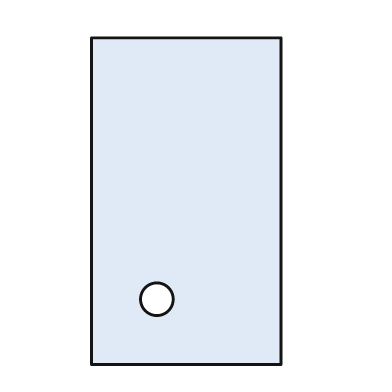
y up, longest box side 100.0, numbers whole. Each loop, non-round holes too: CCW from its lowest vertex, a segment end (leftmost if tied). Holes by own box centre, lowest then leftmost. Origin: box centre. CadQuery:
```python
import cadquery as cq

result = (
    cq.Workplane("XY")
    .moveTo(-29.0, -50.0)
    .lineTo(29.0, -50.0)
    .lineTo(29.0, 50.0)
    .lineTo(-29.0, 50.0)
    .close()
    .moveTo(-9.0, -30.0)
    .circle(5.0)
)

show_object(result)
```